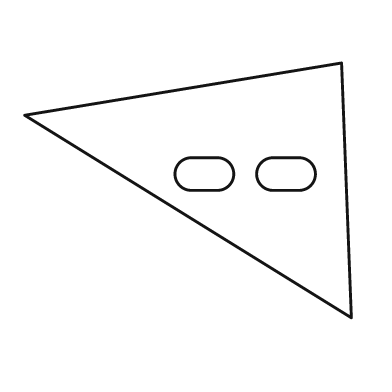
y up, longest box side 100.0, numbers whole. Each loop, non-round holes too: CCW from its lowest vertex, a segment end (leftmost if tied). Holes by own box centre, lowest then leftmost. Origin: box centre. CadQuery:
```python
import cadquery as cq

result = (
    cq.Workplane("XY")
    .moveTo(50.0, -39.0)
    .lineTo(47.0, 39.0)
    .lineTo(-50.0, 23.0)
    .close()
    .moveTo(1.0, 0.0)
    .lineTo(9.0, 0.0)
    .threePointArc((14.0, 5.0), (9.0, 10.0))
    .lineTo(1.0, 10.0)
    .threePointArc((-4.0, 5.0), (1.0, 0.0))
    .close()
    .moveTo(26.0, 0.0)
    .lineTo(34.0, 0.0)
    .threePointArc((39.0, 5.0), (34.0, 10.0))
    .lineTo(26.0, 10.0)
    .threePointArc((21.0, 5.0), (26.0, 0.0))
    .close()
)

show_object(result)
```